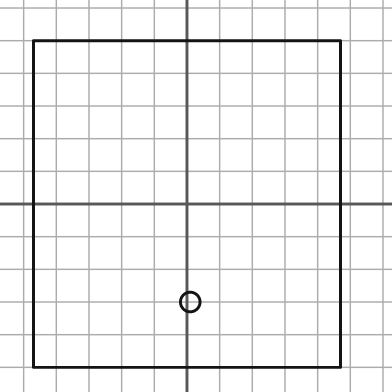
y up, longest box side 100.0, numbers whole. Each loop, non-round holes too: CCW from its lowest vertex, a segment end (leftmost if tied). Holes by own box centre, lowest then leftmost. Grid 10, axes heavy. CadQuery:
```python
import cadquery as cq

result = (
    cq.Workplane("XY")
    .moveTo(-47.0, -50.0)
    .lineTo(47.0, -50.0)
    .lineTo(47.0, 50.0)
    .lineTo(-47.0, 50.0)
    .close()
    .moveTo(1.0, -30.0)
    .circle(3.0)
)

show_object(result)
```